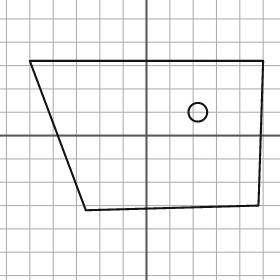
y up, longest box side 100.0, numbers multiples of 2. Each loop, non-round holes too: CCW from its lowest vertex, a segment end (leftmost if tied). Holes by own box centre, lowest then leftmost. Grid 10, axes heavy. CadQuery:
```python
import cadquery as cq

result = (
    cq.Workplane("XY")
    .moveTo(-26.0, -32.0)
    .lineTo(48.0, -30.0)
    .lineTo(50.0, 32.0)
    .lineTo(-50.0, 32.0)
    .close()
    .moveTo(22.0, 10.0)
    .circle(4.0)
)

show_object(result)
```